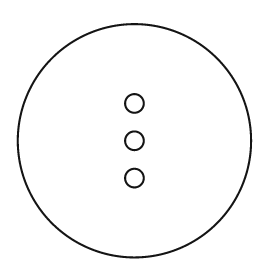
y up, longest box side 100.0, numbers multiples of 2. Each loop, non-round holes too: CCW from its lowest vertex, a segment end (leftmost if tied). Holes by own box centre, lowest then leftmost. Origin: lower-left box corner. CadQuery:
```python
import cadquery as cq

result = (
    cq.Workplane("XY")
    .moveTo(50.0, 50.0)
    .circle(50.0)
    .moveTo(50.0, 34.0)
    .circle(4.0)
    .moveTo(50.0, 50.0)
    .circle(4.0)
    .moveTo(50.0, 66.0)
    .circle(4.0)
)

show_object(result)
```